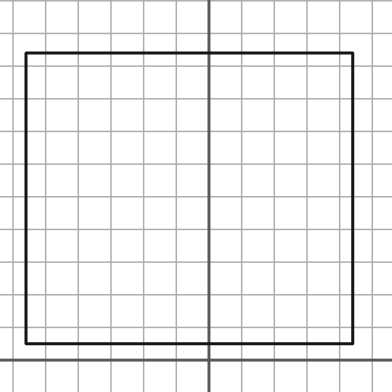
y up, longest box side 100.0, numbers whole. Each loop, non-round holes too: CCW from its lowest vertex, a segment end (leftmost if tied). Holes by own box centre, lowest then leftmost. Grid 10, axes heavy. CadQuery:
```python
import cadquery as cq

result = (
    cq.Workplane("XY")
    .moveTo(-56.0, 5.0)
    .lineTo(44.0, 5.0)
    .lineTo(44.0, 94.0)
    .lineTo(-56.0, 94.0)
    .close()
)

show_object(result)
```